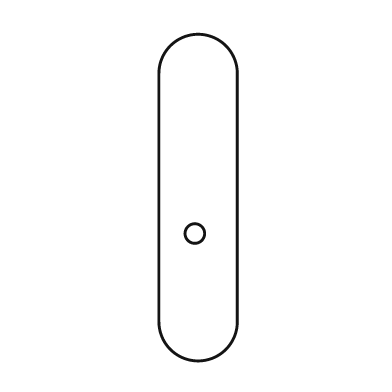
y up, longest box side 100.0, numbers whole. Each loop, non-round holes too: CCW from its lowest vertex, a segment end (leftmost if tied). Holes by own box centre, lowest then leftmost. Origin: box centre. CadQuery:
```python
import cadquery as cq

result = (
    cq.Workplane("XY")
    .moveTo(-12.0, -38.0)
    .threePointArc((0.0, -50.0), (12.0, -38.0))
    .lineTo(12.0, 38.0)
    .threePointArc((0.0, 50.0), (-12.0, 38.0))
    .close()
    .moveTo(-1.0, -11.0)
    .circle(3.0)
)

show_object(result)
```